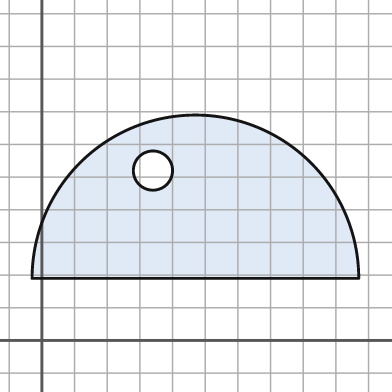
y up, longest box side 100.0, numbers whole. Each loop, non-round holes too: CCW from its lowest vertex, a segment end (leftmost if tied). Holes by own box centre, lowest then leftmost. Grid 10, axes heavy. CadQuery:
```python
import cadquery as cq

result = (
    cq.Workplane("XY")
    .moveTo(-3.0, 19.0)
    .lineTo(97.0, 19.0)
    .threePointArc((47.0, 69.0), (-3.0, 19.0))
    .close()
    .moveTo(34.0, 52.0)
    .circle(6.0)
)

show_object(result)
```